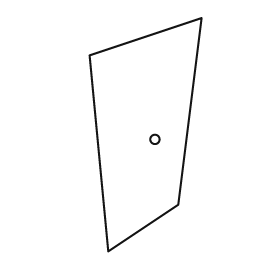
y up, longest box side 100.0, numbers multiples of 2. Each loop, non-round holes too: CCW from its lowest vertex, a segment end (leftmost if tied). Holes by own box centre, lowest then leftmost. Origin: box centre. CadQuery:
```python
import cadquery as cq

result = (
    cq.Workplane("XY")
    .moveTo(-16.0, -50.0)
    .lineTo(14.0, -30.0)
    .lineTo(24.0, 50.0)
    .lineTo(-24.0, 34.0)
    .close()
    .moveTo(4.0, -2.0)
    .circle(2.0)
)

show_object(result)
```